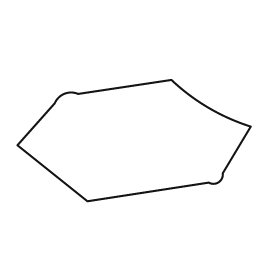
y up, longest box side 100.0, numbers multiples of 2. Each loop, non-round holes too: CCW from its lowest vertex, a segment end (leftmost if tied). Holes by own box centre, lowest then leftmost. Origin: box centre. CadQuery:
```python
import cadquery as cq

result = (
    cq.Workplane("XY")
    .moveTo(-20.0, -26.0)
    .lineTo(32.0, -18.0)
    .threePointArc((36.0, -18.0), (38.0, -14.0))
    .lineTo(50.0, 6.0)
    .threePointArc((32.0, 14.0), (16.0, 26.0))
    .lineTo(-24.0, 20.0)
    .threePointArc((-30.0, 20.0), (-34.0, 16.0))
    .lineTo(-50.0, -2.0)
    .close()
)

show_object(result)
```